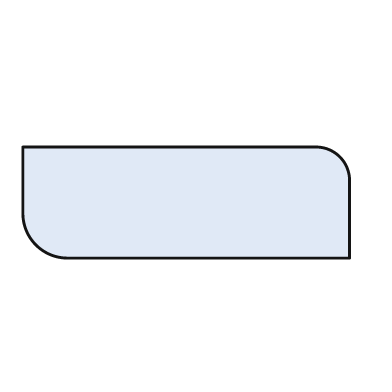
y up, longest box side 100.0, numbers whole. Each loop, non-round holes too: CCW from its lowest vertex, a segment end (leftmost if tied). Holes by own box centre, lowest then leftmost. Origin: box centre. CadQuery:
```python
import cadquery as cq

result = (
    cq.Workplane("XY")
    .moveTo(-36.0, -17.0)
    .lineTo(50.0, -17.0)
    .lineTo(50.0, 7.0)
    .threePointArc((47.0, 14.0), (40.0, 17.0))
    .lineTo(-50.0, 17.0)
    .lineTo(-50.0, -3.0)
    .threePointArc((-46.0, -13.0), (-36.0, -17.0))
    .close()
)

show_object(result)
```